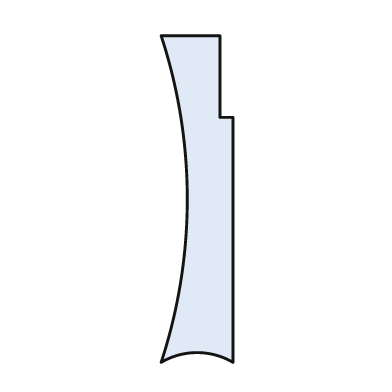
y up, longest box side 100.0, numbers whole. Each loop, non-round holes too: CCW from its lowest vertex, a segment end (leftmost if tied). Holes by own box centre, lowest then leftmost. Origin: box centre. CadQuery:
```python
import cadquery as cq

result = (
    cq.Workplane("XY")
    .moveTo(-11.0, -50.0)
    .threePointArc((0.0, -47.0), (11.0, -50.0))
    .lineTo(11.0, 25.0)
    .lineTo(7.0, 25.0)
    .lineTo(7.0, 50.0)
    .lineTo(-11.0, 50.0)
    .threePointArc((-3.0, 0.0), (-11.0, -50.0))
    .close()
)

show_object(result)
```